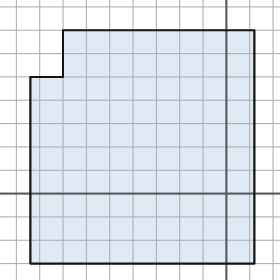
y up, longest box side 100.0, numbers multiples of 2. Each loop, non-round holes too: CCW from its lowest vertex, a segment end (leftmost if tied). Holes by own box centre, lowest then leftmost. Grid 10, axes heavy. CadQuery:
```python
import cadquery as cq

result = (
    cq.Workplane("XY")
    .moveTo(-84.0, -30.0)
    .lineTo(12.0, -30.0)
    .lineTo(12.0, 70.0)
    .lineTo(-70.0, 70.0)
    .lineTo(-70.0, 50.0)
    .lineTo(-84.0, 50.0)
    .close()
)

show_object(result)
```